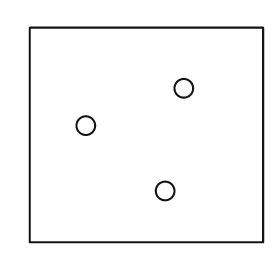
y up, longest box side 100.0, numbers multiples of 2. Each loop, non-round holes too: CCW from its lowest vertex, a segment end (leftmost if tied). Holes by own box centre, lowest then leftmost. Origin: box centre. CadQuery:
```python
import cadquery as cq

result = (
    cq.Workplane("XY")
    .moveTo(-50.0, -46.0)
    .lineTo(50.0, -46.0)
    .lineTo(50.0, 46.0)
    .lineTo(-50.0, 46.0)
    .close()
    .moveTo(8.0, -24.0)
    .circle(4.0)
    .moveTo(-26.0, 4.0)
    .circle(4.0)
    .moveTo(16.0, 20.0)
    .circle(4.0)
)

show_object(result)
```